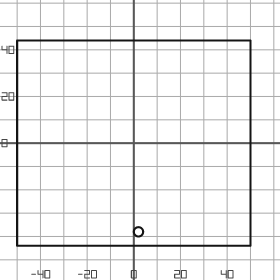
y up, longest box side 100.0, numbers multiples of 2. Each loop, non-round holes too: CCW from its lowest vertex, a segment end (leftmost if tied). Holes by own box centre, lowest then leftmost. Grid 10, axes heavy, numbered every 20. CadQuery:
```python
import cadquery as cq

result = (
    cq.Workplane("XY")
    .moveTo(-50.0, -44.0)
    .lineTo(50.0, -44.0)
    .lineTo(50.0, 44.0)
    .lineTo(-50.0, 44.0)
    .close()
    .moveTo(2.0, -38.0)
    .circle(2.0)
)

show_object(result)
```